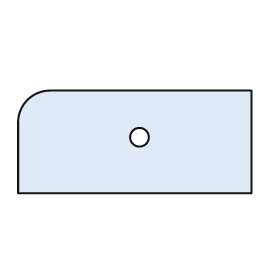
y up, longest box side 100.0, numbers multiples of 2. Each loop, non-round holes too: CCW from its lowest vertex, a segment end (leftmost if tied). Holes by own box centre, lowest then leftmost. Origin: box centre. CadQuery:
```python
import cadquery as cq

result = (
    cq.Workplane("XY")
    .moveTo(-50.0, -22.0)
    .lineTo(50.0, -22.0)
    .lineTo(50.0, 22.0)
    .lineTo(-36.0, 22.0)
    .threePointArc((-46.0, 18.0), (-50.0, 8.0))
    .close()
    .moveTo(2.0, 2.0)
    .circle(4.0)
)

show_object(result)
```